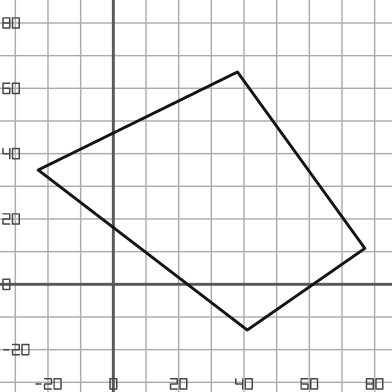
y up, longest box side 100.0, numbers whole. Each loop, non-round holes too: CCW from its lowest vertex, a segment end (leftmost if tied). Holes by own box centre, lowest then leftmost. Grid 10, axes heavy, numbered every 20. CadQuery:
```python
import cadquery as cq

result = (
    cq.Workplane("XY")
    .moveTo(41.0, -14.0)
    .lineTo(77.0, 11.0)
    .lineTo(38.0, 65.0)
    .lineTo(-23.0, 35.0)
    .close()
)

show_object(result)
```